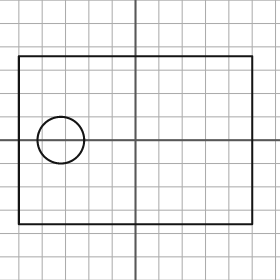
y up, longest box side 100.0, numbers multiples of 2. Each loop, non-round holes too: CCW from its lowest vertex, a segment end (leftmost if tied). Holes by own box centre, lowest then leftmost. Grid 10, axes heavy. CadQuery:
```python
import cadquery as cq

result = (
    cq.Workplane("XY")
    .moveTo(-50.0, -36.0)
    .lineTo(50.0, -36.0)
    .lineTo(50.0, 36.0)
    .lineTo(-50.0, 36.0)
    .close()
    .moveTo(-32.0, 0.0)
    .circle(10.0)
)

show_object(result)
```